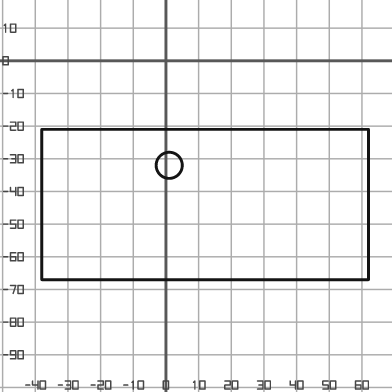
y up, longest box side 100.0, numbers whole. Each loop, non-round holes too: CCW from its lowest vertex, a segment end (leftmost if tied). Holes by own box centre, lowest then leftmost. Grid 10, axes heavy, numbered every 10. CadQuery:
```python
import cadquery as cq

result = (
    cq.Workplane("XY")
    .moveTo(-38.0, -67.0)
    .lineTo(62.0, -67.0)
    .lineTo(62.0, -21.0)
    .lineTo(-38.0, -21.0)
    .close()
    .moveTo(1.0, -32.0)
    .circle(4.0)
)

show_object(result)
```